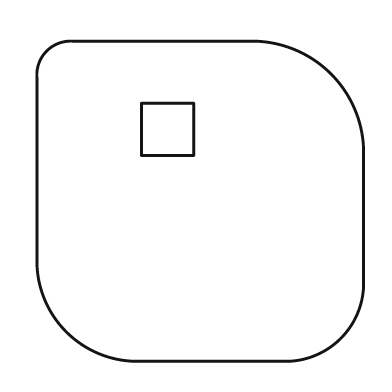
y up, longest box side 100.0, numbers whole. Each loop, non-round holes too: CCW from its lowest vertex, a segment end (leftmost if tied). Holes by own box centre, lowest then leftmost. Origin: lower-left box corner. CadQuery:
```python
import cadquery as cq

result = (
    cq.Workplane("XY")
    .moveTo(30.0, 0.0)
    .lineTo(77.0, 0.0)
    .threePointArc((93.0, 7.0), (100.0, 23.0))
    .lineTo(100.0, 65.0)
    .threePointArc((90.0, 88.0), (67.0, 98.0))
    .lineTo(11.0, 98.0)
    .threePointArc((3.0, 95.0), (0.0, 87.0))
    .lineTo(0.0, 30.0)
    .threePointArc((9.0, 9.0), (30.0, 0.0))
    .close()
    .moveTo(32.0, 63.0)
    .lineTo(48.0, 63.0)
    .lineTo(48.0, 79.0)
    .lineTo(32.0, 79.0)
    .close()
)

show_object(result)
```